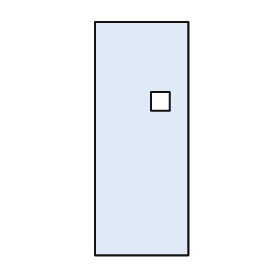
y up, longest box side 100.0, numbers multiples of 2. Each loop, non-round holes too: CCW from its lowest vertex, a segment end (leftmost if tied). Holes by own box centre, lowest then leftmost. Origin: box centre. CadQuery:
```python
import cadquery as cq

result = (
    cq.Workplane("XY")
    .moveTo(-20.0, -50.0)
    .lineTo(20.0, -50.0)
    .lineTo(20.0, 50.0)
    .lineTo(-20.0, 50.0)
    .close()
    .moveTo(4.0, 12.0)
    .lineTo(12.0, 12.0)
    .lineTo(12.0, 20.0)
    .lineTo(4.0, 20.0)
    .close()
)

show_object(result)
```